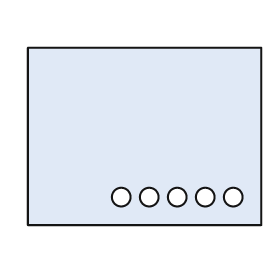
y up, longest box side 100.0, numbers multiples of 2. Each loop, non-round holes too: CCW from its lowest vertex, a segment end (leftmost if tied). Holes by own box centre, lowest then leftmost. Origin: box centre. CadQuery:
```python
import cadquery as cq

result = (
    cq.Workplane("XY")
    .moveTo(-50.0, -38.0)
    .lineTo(50.0, -38.0)
    .lineTo(50.0, 38.0)
    .lineTo(-50.0, 38.0)
    .close()
    .moveTo(-10.0, -26.0)
    .circle(4.0)
    .moveTo(2.0, -26.0)
    .circle(4.0)
    .moveTo(14.0, -26.0)
    .circle(4.0)
    .moveTo(26.0, -26.0)
    .circle(4.0)
    .moveTo(38.0, -26.0)
    .circle(4.0)
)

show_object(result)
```